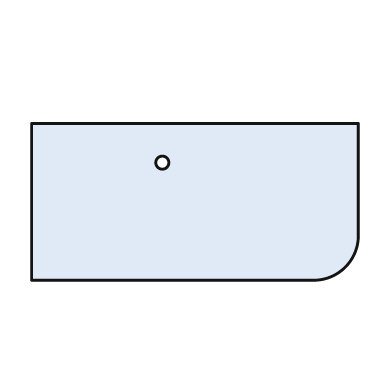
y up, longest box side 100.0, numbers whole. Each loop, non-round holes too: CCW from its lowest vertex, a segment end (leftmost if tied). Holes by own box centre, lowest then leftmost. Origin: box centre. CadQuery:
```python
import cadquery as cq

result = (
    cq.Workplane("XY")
    .moveTo(-50.0, -24.0)
    .lineTo(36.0, -24.0)
    .threePointArc((46.0, -20.0), (50.0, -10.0))
    .lineTo(50.0, 24.0)
    .lineTo(-50.0, 24.0)
    .close()
    .moveTo(-10.0, 12.0)
    .circle(2.0)
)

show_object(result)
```